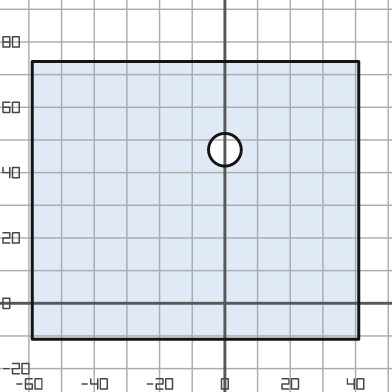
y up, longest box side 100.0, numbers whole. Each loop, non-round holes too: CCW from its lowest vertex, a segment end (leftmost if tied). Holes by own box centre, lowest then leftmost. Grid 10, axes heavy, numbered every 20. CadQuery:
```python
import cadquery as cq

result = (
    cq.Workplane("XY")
    .moveTo(-59.0, -11.0)
    .lineTo(41.0, -11.0)
    .lineTo(41.0, 74.0)
    .lineTo(-59.0, 74.0)
    .close()
    .moveTo(0.0, 47.0)
    .circle(5.0)
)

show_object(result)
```